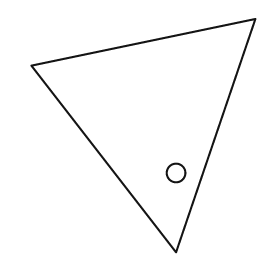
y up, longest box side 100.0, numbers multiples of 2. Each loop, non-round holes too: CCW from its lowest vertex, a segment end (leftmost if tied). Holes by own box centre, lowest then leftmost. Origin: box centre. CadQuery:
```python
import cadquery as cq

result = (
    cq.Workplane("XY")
    .moveTo(14.0, -50.0)
    .lineTo(48.0, 50.0)
    .lineTo(-48.0, 30.0)
    .close()
    .moveTo(14.0, -16.0)
    .circle(4.0)
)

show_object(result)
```